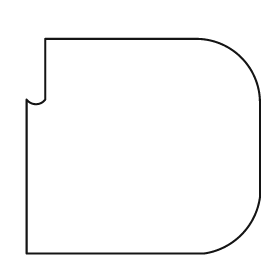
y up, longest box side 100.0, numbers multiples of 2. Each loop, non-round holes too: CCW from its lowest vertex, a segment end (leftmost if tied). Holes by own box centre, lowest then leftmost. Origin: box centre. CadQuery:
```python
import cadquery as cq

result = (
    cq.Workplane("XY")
    .moveTo(-50.0, -46.0)
    .lineTo(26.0, -46.0)
    .threePointArc((42.0, -38.0), (50.0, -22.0))
    .lineTo(50.0, 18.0)
    .threePointArc((42.0, 38.0), (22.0, 46.0))
    .lineTo(-42.0, 46.0)
    .lineTo(-42.0, 20.0)
    .threePointArc((-46.0, 18.0), (-50.0, 20.0))
    .close()
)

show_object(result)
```